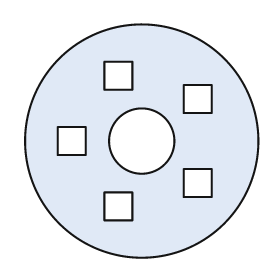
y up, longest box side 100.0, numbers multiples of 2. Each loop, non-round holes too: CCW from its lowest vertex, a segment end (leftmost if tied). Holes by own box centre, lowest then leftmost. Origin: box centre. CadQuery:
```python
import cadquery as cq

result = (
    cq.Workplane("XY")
    .moveTo(0.0, 0.0)
    .circle(50.0)
    .moveTo(-16.0, -34.0)
    .lineTo(-4.0, -34.0)
    .lineTo(-4.0, -22.0)
    .lineTo(-16.0, -22.0)
    .close()
    .moveTo(18.0, -24.0)
    .lineTo(30.0, -24.0)
    .lineTo(30.0, -12.0)
    .lineTo(18.0, -12.0)
    .close()
    .moveTo(-36.0, -6.0)
    .lineTo(-24.0, -6.0)
    .lineTo(-24.0, 6.0)
    .lineTo(-36.0, 6.0)
    .close()
    .moveTo(0.0, 0.0)
    .circle(14.0)
    .moveTo(18.0, 12.0)
    .lineTo(30.0, 12.0)
    .lineTo(30.0, 24.0)
    .lineTo(18.0, 24.0)
    .close()
    .moveTo(-16.0, 22.0)
    .lineTo(-4.0, 22.0)
    .lineTo(-4.0, 34.0)
    .lineTo(-16.0, 34.0)
    .close()
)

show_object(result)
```